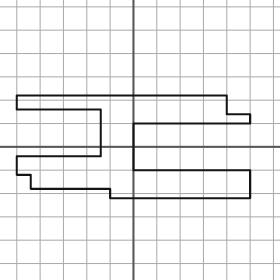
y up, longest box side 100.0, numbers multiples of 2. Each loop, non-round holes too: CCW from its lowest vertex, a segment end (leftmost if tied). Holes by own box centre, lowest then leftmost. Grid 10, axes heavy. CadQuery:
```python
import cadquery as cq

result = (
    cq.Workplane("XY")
    .moveTo(-10.0, -22.0)
    .lineTo(50.0, -22.0)
    .lineTo(50.0, -10.0)
    .lineTo(0.0, -10.0)
    .lineTo(0.0, 10.0)
    .lineTo(50.0, 10.0)
    .lineTo(50.0, 14.0)
    .lineTo(40.0, 14.0)
    .lineTo(40.0, 22.0)
    .lineTo(-50.0, 22.0)
    .lineTo(-50.0, 16.0)
    .lineTo(-14.0, 16.0)
    .lineTo(-14.0, -4.0)
    .lineTo(-50.0, -4.0)
    .lineTo(-50.0, -12.0)
    .lineTo(-44.0, -12.0)
    .lineTo(-44.0, -18.0)
    .lineTo(-10.0, -18.0)
    .close()
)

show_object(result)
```